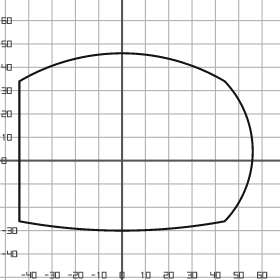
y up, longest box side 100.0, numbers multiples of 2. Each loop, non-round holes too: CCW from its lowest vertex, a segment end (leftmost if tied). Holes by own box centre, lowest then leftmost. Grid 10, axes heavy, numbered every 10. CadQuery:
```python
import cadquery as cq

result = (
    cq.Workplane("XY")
    .moveTo(-44.0, -26.0)
    .threePointArc((0.0, -30.0), (44.0, -26.0))
    .threePointArc((56.0, 4.0), (44.0, 34.0))
    .threePointArc((0.0, 46.0), (-44.0, 34.0))
    .close()
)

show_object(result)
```